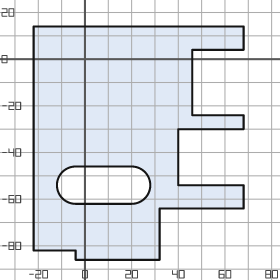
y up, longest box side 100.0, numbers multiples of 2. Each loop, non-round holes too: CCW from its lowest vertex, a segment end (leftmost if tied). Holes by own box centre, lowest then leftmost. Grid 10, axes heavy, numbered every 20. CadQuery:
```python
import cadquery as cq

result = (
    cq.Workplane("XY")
    .moveTo(-4.0, -86.0)
    .lineTo(32.0, -86.0)
    .lineTo(32.0, -64.0)
    .lineTo(68.0, -64.0)
    .lineTo(68.0, -54.0)
    .lineTo(40.0, -54.0)
    .lineTo(40.0, -30.0)
    .lineTo(68.0, -30.0)
    .lineTo(68.0, -24.0)
    .lineTo(46.0, -24.0)
    .lineTo(46.0, 4.0)
    .lineTo(68.0, 4.0)
    .lineTo(68.0, 14.0)
    .lineTo(-22.0, 14.0)
    .lineTo(-22.0, -82.0)
    .lineTo(-4.0, -82.0)
    .close()
    .moveTo(-4.0, -62.0)
    .lineTo(20.0, -62.0)
    .threePointArc((28.0, -54.0), (20.0, -46.0))
    .lineTo(-4.0, -46.0)
    .threePointArc((-12.0, -54.0), (-4.0, -62.0))
    .close()
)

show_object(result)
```